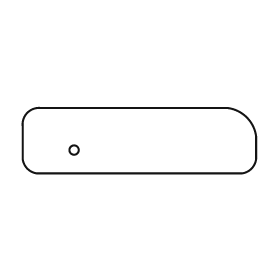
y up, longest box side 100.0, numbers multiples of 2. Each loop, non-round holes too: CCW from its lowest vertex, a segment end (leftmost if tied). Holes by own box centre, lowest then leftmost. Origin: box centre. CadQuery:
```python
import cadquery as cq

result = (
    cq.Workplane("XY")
    .moveTo(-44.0, -14.0)
    .lineTo(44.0, -14.0)
    .threePointArc((48.0, -12.0), (50.0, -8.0))
    .lineTo(50.0, 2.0)
    .threePointArc((46.0, 10.0), (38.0, 14.0))
    .lineTo(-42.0, 14.0)
    .threePointArc((-48.0, 12.0), (-50.0, 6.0))
    .lineTo(-50.0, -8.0)
    .threePointArc((-48.0, -12.0), (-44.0, -14.0))
    .close()
    .moveTo(-28.0, -4.0)
    .circle(2.0)
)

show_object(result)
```